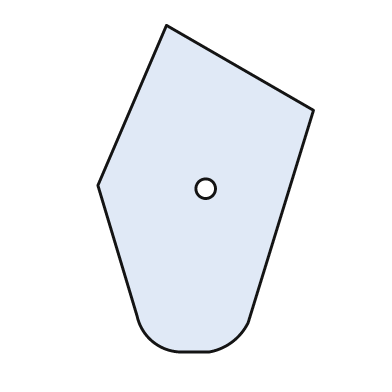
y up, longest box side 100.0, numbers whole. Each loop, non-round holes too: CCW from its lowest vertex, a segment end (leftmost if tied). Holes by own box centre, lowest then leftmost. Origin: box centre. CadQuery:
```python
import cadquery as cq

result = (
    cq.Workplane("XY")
    .moveTo(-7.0, -50.0)
    .lineTo(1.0, -50.0)
    .threePointArc((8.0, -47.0), (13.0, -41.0))
    .lineTo(33.0, 24.0)
    .lineTo(-12.0, 50.0)
    .lineTo(-33.0, 1.0)
    .lineTo(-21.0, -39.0)
    .threePointArc((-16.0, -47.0), (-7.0, -50.0))
    .close()
    .moveTo(0.0, 0.0)
    .circle(3.0)
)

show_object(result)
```